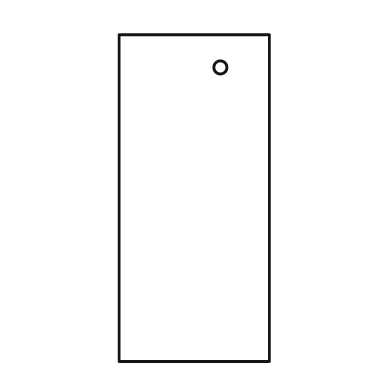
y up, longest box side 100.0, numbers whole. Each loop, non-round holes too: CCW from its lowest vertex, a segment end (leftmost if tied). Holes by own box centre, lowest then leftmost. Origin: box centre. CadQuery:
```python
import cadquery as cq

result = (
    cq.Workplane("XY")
    .moveTo(-23.0, -50.0)
    .lineTo(23.0, -50.0)
    .lineTo(23.0, 50.0)
    .lineTo(-23.0, 50.0)
    .close()
    .moveTo(8.0, 40.0)
    .circle(2.0)
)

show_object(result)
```